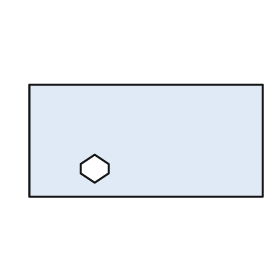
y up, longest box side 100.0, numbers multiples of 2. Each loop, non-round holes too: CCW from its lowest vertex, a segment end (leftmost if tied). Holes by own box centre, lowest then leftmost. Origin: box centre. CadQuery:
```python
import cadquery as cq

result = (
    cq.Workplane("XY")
    .moveTo(-50.0, -24.0)
    .lineTo(50.0, -24.0)
    .lineTo(50.0, 24.0)
    .lineTo(-50.0, 24.0)
    .close()
    .moveTo(-22.0, -18.0)
    .lineTo(-16.0, -14.0)
    .lineTo(-16.0, -10.0)
    .lineTo(-22.0, -6.0)
    .lineTo(-28.0, -10.0)
    .lineTo(-28.0, -14.0)
    .close()
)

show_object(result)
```